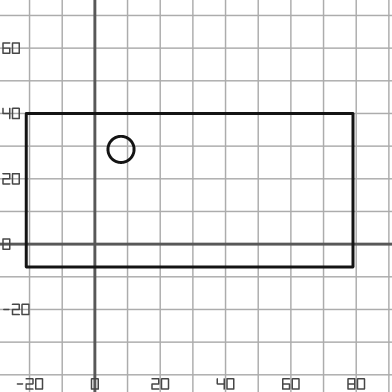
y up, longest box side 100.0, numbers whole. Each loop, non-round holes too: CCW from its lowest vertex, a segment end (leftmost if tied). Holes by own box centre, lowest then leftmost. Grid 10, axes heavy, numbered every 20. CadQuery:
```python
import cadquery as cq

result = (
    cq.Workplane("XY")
    .moveTo(-21.0, -7.0)
    .lineTo(79.0, -7.0)
    .lineTo(79.0, 40.0)
    .lineTo(-21.0, 40.0)
    .close()
    .moveTo(8.0, 29.0)
    .circle(4.0)
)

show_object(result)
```